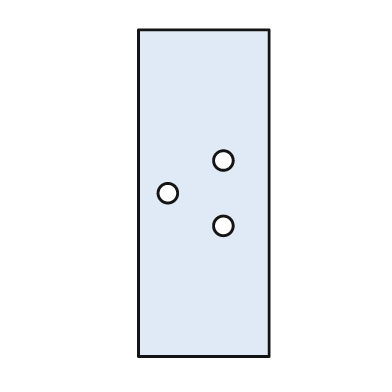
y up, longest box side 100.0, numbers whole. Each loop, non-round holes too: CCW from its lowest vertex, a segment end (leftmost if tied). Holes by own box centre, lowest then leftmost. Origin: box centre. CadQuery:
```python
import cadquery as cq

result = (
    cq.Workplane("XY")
    .moveTo(-20.0, -50.0)
    .lineTo(20.0, -50.0)
    .lineTo(20.0, 50.0)
    .lineTo(-20.0, 50.0)
    .close()
    .moveTo(6.0, -10.0)
    .circle(3.0)
    .moveTo(-11.0, 0.0)
    .circle(3.0)
    .moveTo(6.0, 10.0)
    .circle(3.0)
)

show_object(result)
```